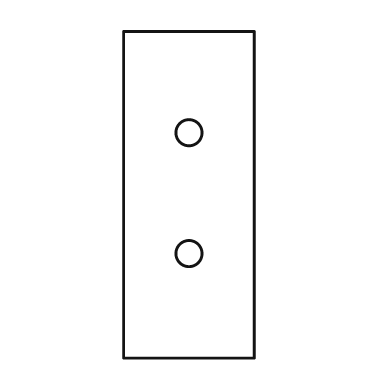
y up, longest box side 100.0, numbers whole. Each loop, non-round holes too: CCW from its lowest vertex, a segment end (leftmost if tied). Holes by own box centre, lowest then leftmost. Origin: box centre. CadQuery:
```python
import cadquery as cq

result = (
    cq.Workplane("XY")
    .moveTo(-20.0, -50.0)
    .lineTo(20.0, -50.0)
    .lineTo(20.0, 50.0)
    .lineTo(-20.0, 50.0)
    .close()
    .moveTo(0.0, -18.0)
    .circle(4.0)
    .moveTo(0.0, 19.0)
    .circle(4.0)
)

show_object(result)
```